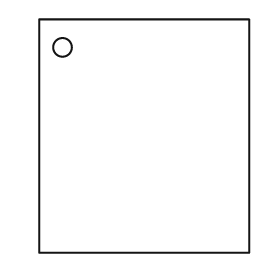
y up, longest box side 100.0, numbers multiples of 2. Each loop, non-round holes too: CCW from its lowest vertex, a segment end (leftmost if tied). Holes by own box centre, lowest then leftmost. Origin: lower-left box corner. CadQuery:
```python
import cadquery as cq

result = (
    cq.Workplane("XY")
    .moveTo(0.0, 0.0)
    .lineTo(90.0, 0.0)
    .lineTo(90.0, 100.0)
    .lineTo(0.0, 100.0)
    .close()
    .moveTo(10.0, 88.0)
    .circle(4.0)
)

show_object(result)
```